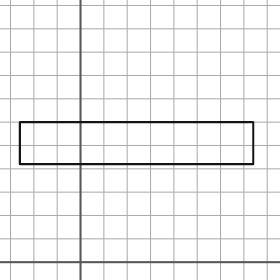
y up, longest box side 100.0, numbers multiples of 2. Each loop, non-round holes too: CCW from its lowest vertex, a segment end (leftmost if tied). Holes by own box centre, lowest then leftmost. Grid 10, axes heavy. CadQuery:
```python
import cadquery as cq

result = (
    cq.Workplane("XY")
    .moveTo(-26.0, 42.0)
    .lineTo(74.0, 42.0)
    .lineTo(74.0, 60.0)
    .lineTo(-26.0, 60.0)
    .close()
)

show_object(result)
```